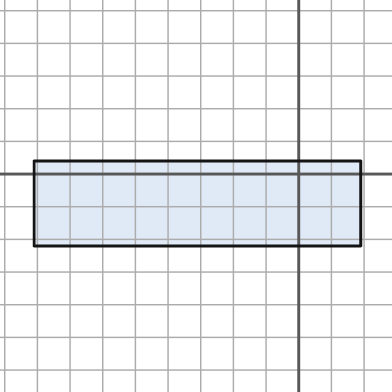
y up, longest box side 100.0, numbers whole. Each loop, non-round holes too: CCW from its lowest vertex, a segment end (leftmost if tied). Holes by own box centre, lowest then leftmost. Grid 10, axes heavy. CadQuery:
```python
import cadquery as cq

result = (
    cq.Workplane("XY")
    .moveTo(-81.0, -22.0)
    .lineTo(19.0, -22.0)
    .lineTo(19.0, 4.0)
    .lineTo(-81.0, 4.0)
    .close()
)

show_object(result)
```